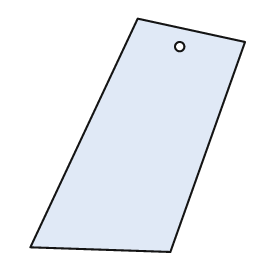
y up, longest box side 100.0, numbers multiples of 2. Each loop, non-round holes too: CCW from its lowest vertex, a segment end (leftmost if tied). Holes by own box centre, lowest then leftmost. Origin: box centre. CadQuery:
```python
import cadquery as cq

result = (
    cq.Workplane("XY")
    .moveTo(14.0, -50.0)
    .lineTo(46.0, 40.0)
    .lineTo(0.0, 50.0)
    .lineTo(-46.0, -48.0)
    .close()
    .moveTo(18.0, 38.0)
    .circle(2.0)
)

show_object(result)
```